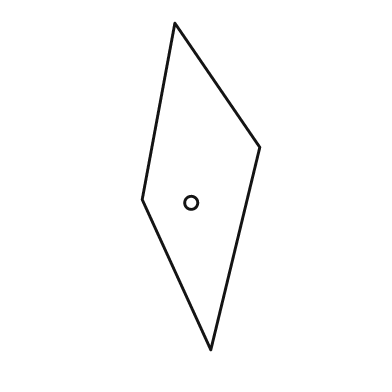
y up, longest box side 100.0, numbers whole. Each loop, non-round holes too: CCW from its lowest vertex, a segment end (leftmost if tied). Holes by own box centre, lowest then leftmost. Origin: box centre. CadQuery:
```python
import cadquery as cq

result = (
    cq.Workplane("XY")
    .moveTo(3.0, -50.0)
    .lineTo(18.0, 12.0)
    .lineTo(-8.0, 50.0)
    .lineTo(-18.0, -4.0)
    .close()
    .moveTo(-3.0, -5.0)
    .circle(2.0)
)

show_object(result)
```